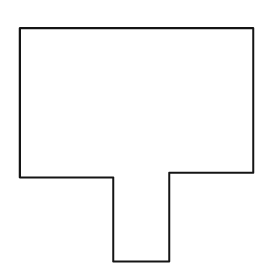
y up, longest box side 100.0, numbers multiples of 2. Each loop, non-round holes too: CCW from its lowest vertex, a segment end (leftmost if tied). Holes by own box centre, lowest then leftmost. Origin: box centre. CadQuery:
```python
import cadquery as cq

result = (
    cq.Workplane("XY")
    .moveTo(-10.0, -50.0)
    .lineTo(14.0, -50.0)
    .lineTo(14.0, -12.0)
    .lineTo(50.0, -12.0)
    .lineTo(50.0, 50.0)
    .lineTo(-50.0, 50.0)
    .lineTo(-50.0, -14.0)
    .lineTo(-10.0, -14.0)
    .close()
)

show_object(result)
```